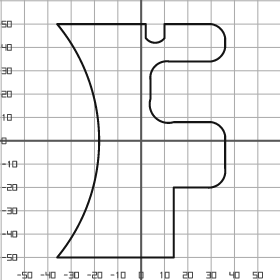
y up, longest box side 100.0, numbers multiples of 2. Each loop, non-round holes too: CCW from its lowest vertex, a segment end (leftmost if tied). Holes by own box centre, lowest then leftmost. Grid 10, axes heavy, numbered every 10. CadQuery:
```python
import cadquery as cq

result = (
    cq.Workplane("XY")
    .moveTo(-36.0, -50.0)
    .lineTo(14.0, -50.0)
    .lineTo(14.0, -20.0)
    .lineTo(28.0, -20.0)
    .threePointArc((34.0, -18.0), (36.0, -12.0))
    .lineTo(36.0, 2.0)
    .threePointArc((34.0, 6.0), (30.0, 8.0))
    .lineTo(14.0, 8.0)
    .threePointArc((6.0, 10.0), (4.0, 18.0))
    .lineTo(4.0, 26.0)
    .threePointArc((6.0, 32.0), (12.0, 34.0))
    .lineTo(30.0, 34.0)
    .threePointArc((34.0, 36.0), (36.0, 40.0))
    .lineTo(36.0, 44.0)
    .threePointArc((34.0, 48.0), (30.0, 50.0))
    .lineTo(10.0, 50.0)
    .lineTo(10.0, 44.0)
    .threePointArc((6.0, 42.0), (2.0, 44.0))
    .lineTo(2.0, 50.0)
    .lineTo(-36.0, 50.0)
    .threePointArc((-18.0, 0.0), (-36.0, -50.0))
    .close()
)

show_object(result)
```